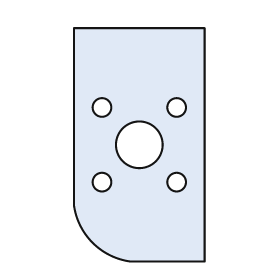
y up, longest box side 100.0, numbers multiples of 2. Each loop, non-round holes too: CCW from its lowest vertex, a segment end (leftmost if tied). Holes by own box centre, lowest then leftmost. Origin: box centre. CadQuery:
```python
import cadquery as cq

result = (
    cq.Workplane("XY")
    .moveTo(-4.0, -50.0)
    .lineTo(28.0, -50.0)
    .lineTo(28.0, 50.0)
    .lineTo(-28.0, 50.0)
    .lineTo(-28.0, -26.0)
    .threePointArc((-20.0, -42.0), (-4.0, -50.0))
    .close()
    .moveTo(-16.0, -16.0)
    .circle(4.0)
    .moveTo(16.0, -16.0)
    .circle(4.0)
    .moveTo(0.0, 0.0)
    .circle(10.0)
    .moveTo(-16.0, 16.0)
    .circle(4.0)
    .moveTo(16.0, 16.0)
    .circle(4.0)
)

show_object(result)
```